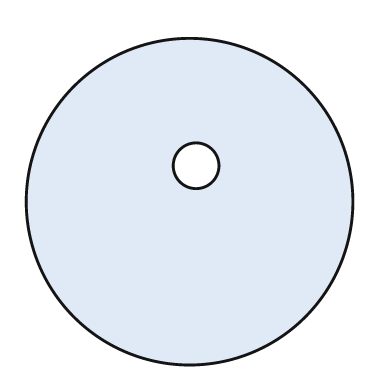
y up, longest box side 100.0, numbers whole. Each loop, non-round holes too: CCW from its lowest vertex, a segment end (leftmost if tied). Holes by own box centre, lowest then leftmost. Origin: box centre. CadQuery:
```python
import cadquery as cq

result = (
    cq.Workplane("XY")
    .moveTo(0.0, 0.0)
    .circle(50.0)
    .moveTo(2.0, 11.0)
    .circle(7.0)
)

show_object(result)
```